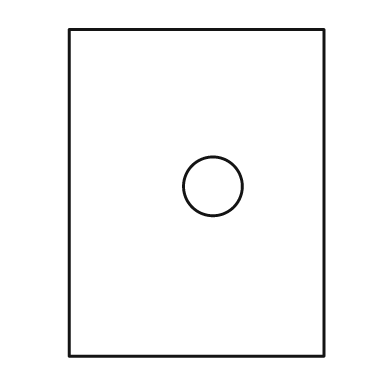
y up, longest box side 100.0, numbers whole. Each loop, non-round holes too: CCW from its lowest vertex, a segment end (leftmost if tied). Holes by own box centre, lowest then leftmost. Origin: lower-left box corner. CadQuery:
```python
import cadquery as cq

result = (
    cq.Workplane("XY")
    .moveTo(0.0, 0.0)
    .lineTo(78.0, 0.0)
    .lineTo(78.0, 100.0)
    .lineTo(0.0, 100.0)
    .close()
    .moveTo(44.0, 52.0)
    .circle(9.0)
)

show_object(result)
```